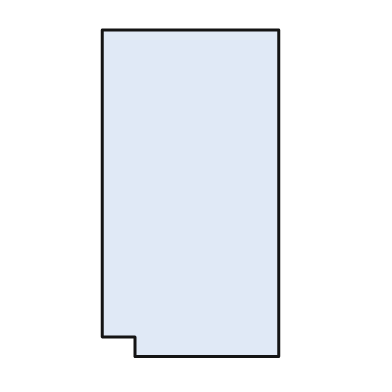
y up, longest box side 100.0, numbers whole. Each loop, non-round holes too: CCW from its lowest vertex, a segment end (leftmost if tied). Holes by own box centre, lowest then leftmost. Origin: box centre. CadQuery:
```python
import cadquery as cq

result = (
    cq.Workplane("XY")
    .moveTo(-17.0, -50.0)
    .lineTo(27.0, -50.0)
    .lineTo(27.0, 50.0)
    .lineTo(-27.0, 50.0)
    .lineTo(-27.0, -44.0)
    .lineTo(-17.0, -44.0)
    .close()
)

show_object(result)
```